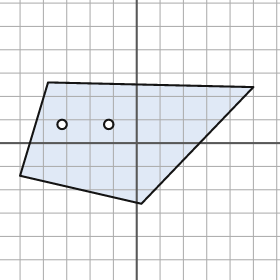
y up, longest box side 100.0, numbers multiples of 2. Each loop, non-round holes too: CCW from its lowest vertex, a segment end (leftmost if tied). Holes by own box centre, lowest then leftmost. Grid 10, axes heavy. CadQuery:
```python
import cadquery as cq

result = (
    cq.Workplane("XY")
    .moveTo(2.0, -26.0)
    .lineTo(50.0, 24.0)
    .lineTo(-38.0, 26.0)
    .lineTo(-50.0, -14.0)
    .close()
    .moveTo(-32.0, 8.0)
    .circle(2.0)
    .moveTo(-12.0, 8.0)
    .circle(2.0)
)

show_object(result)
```